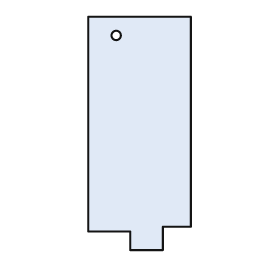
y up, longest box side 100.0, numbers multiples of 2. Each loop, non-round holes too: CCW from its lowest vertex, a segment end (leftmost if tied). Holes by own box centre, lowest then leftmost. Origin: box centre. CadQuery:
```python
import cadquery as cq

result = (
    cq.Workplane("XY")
    .moveTo(-4.0, -50.0)
    .lineTo(10.0, -50.0)
    .lineTo(10.0, -40.0)
    .lineTo(22.0, -40.0)
    .lineTo(22.0, 50.0)
    .lineTo(-22.0, 50.0)
    .lineTo(-22.0, -42.0)
    .lineTo(-4.0, -42.0)
    .close()
    .moveTo(-10.0, 42.0)
    .circle(2.0)
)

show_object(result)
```